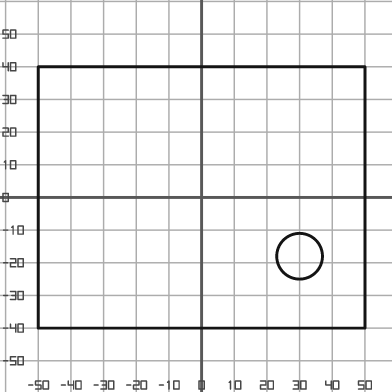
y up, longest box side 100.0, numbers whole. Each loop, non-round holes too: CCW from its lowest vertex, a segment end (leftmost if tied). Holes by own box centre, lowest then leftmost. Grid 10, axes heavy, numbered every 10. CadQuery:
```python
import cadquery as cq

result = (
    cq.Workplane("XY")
    .moveTo(-50.0, -40.0)
    .lineTo(50.0, -40.0)
    .lineTo(50.0, 40.0)
    .lineTo(-50.0, 40.0)
    .close()
    .moveTo(30.0, -18.0)
    .circle(7.0)
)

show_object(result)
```